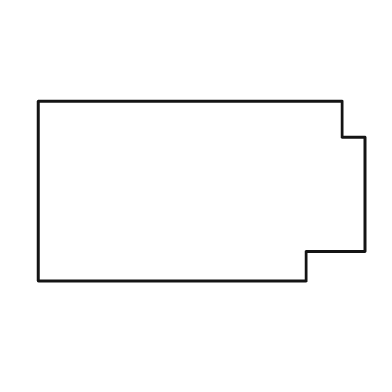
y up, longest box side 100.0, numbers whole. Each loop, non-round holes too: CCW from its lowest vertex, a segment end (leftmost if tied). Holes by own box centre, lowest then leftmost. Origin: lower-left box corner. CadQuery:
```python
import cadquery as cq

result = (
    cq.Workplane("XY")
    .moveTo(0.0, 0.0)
    .lineTo(82.0, 0.0)
    .lineTo(82.0, 9.0)
    .lineTo(100.0, 9.0)
    .lineTo(100.0, 44.0)
    .lineTo(93.0, 44.0)
    .lineTo(93.0, 55.0)
    .lineTo(0.0, 55.0)
    .close()
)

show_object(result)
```